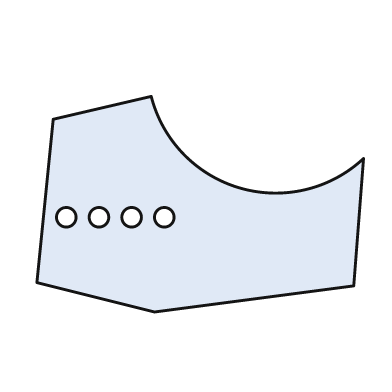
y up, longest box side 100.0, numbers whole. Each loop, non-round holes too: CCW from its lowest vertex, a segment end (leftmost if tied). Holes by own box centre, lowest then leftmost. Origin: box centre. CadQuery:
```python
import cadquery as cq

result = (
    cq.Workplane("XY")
    .moveTo(-14.0, -33.0)
    .lineTo(47.0, -25.0)
    .lineTo(50.0, 14.0)
    .threePointArc((12.0, 5.0), (-15.0, 33.0))
    .lineTo(-45.0, 26.0)
    .lineTo(-50.0, -24.0)
    .close()
    .moveTo(-41.0, -4.0)
    .circle(3.0)
    .moveTo(-31.0, -4.0)
    .circle(3.0)
    .moveTo(-21.0, -4.0)
    .circle(3.0)
    .moveTo(-11.0, -4.0)
    .circle(3.0)
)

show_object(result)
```